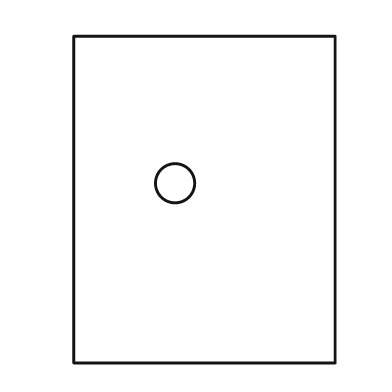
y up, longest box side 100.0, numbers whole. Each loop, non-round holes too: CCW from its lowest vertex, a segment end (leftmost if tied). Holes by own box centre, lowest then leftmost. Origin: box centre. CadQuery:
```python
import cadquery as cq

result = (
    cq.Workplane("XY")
    .moveTo(-40.0, -50.0)
    .lineTo(40.0, -50.0)
    .lineTo(40.0, 50.0)
    .lineTo(-40.0, 50.0)
    .close()
    .moveTo(-9.0, 5.0)
    .circle(6.0)
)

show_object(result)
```